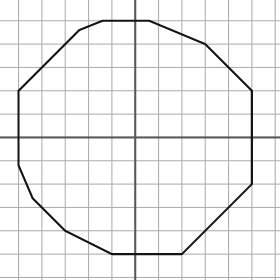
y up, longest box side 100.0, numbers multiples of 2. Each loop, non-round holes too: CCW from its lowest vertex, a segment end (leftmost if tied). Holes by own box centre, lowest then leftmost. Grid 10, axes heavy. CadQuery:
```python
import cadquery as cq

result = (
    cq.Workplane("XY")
    .moveTo(-10.0, -50.0)
    .lineTo(20.0, -50.0)
    .lineTo(50.0, -20.0)
    .lineTo(50.0, 20.0)
    .lineTo(30.0, 40.0)
    .lineTo(6.0, 50.0)
    .lineTo(-14.0, 50.0)
    .lineTo(-24.0, 46.0)
    .lineTo(-50.0, 20.0)
    .lineTo(-50.0, -12.0)
    .lineTo(-44.0, -26.0)
    .lineTo(-30.0, -40.0)
    .close()
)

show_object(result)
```